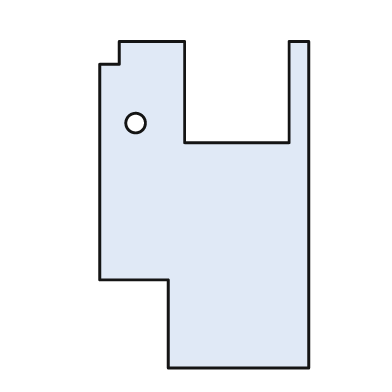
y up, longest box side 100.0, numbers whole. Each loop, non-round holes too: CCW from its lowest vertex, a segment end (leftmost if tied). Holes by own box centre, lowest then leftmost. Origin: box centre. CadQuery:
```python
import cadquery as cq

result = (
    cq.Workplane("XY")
    .moveTo(-11.0, -50.0)
    .lineTo(32.0, -50.0)
    .lineTo(32.0, 50.0)
    .lineTo(26.0, 50.0)
    .lineTo(26.0, 19.0)
    .lineTo(-6.0, 19.0)
    .lineTo(-6.0, 50.0)
    .lineTo(-26.0, 50.0)
    .lineTo(-26.0, 43.0)
    .lineTo(-32.0, 43.0)
    .lineTo(-32.0, -23.0)
    .lineTo(-11.0, -23.0)
    .close()
    .moveTo(-21.0, 25.0)
    .circle(3.0)
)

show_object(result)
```